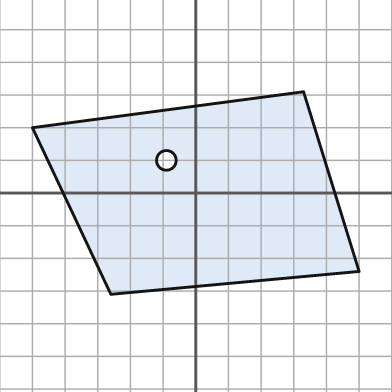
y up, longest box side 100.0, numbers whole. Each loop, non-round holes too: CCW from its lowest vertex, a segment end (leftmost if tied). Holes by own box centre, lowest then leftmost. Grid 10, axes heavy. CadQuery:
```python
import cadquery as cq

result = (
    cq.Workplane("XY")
    .moveTo(-26.0, -31.0)
    .lineTo(50.0, -24.0)
    .lineTo(33.0, 31.0)
    .lineTo(-50.0, 20.0)
    .close()
    .moveTo(-9.0, 10.0)
    .circle(3.0)
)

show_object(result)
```